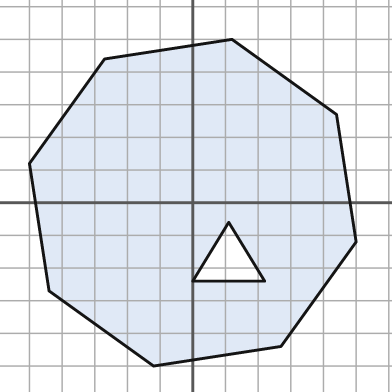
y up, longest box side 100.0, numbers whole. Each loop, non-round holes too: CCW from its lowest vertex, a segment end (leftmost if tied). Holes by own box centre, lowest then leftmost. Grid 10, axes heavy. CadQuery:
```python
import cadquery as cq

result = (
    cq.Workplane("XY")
    .moveTo(-12.0, -50.0)
    .lineTo(27.0, -44.0)
    .lineTo(50.0, -12.0)
    .lineTo(44.0, 27.0)
    .lineTo(12.0, 50.0)
    .lineTo(-27.0, 44.0)
    .lineTo(-50.0, 12.0)
    .lineTo(-44.0, -27.0)
    .close()
    .moveTo(0.0, -24.0)
    .lineTo(22.0, -24.0)
    .lineTo(11.0, -6.0)
    .close()
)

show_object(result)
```